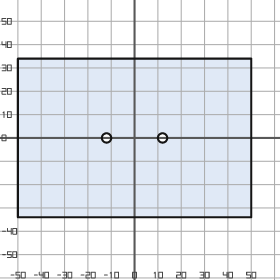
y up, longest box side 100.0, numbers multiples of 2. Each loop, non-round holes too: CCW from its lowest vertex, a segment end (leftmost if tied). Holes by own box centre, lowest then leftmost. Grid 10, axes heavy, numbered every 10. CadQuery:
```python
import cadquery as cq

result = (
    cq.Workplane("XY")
    .moveTo(-50.0, -34.0)
    .lineTo(50.0, -34.0)
    .lineTo(50.0, 34.0)
    .lineTo(-50.0, 34.0)
    .close()
    .moveTo(-12.0, 0.0)
    .circle(2.0)
    .moveTo(12.0, 0.0)
    .circle(2.0)
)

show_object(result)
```